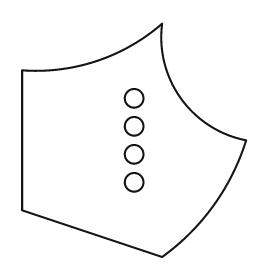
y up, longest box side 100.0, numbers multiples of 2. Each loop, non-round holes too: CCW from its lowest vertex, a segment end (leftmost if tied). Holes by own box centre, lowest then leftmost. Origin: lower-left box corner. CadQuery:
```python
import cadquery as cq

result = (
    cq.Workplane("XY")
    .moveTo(60.0, 0.0)
    .threePointArc((82.0, 22.0), (96.0, 50.0))
    .threePointArc((68.0, 68.0), (60.0, 100.0))
    .threePointArc((32.0, 84.0), (0.0, 80.0))
    .lineTo(0.0, 20.0)
    .close()
    .moveTo(48.0, 32.0)
    .circle(4.0)
    .moveTo(48.0, 44.0)
    .circle(4.0)
    .moveTo(48.0, 56.0)
    .circle(4.0)
    .moveTo(48.0, 68.0)
    .circle(4.0)
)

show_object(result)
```